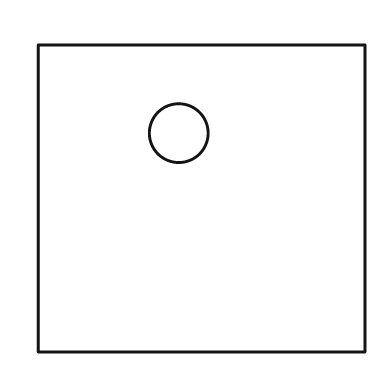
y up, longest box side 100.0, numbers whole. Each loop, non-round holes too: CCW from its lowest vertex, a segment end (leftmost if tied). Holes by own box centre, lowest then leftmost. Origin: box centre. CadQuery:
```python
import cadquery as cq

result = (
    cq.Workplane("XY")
    .moveTo(-50.0, -47.0)
    .lineTo(50.0, -47.0)
    .lineTo(50.0, 47.0)
    .lineTo(-50.0, 47.0)
    .close()
    .moveTo(-7.0, 20.0)
    .circle(9.0)
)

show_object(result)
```